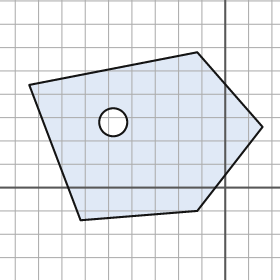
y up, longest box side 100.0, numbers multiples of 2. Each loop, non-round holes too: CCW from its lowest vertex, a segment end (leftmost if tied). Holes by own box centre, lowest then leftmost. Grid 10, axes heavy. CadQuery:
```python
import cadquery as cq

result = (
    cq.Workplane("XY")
    .moveTo(-62.0, -14.0)
    .lineTo(-12.0, -10.0)
    .lineTo(16.0, 26.0)
    .lineTo(-12.0, 58.0)
    .lineTo(-84.0, 44.0)
    .close()
    .moveTo(-48.0, 28.0)
    .circle(6.0)
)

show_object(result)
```